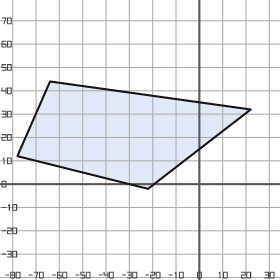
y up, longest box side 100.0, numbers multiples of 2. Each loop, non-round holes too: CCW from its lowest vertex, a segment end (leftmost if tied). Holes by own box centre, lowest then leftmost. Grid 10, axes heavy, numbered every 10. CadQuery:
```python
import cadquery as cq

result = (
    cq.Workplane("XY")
    .moveTo(-22.0, -2.0)
    .lineTo(22.0, 32.0)
    .lineTo(-64.0, 44.0)
    .lineTo(-78.0, 12.0)
    .close()
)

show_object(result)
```